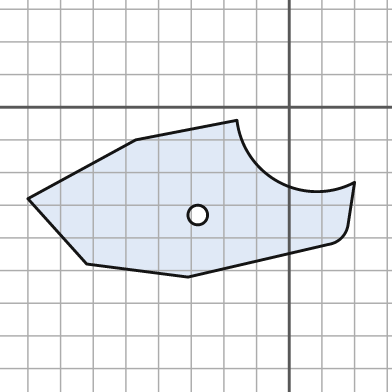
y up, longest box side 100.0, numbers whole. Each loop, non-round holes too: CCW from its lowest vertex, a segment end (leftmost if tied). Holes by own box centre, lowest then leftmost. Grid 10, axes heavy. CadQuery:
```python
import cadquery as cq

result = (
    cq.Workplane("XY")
    .moveTo(-31.0, -52.0)
    .lineTo(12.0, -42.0)
    .threePointArc((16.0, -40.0), (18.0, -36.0))
    .lineTo(20.0, -23.0)
    .threePointArc((-3.0, -23.0), (-16.0, -4.0))
    .lineTo(-47.0, -10.0)
    .lineTo(-80.0, -28.0)
    .lineTo(-62.0, -48.0)
    .close()
    .moveTo(-28.0, -33.0)
    .circle(3.0)
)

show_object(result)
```